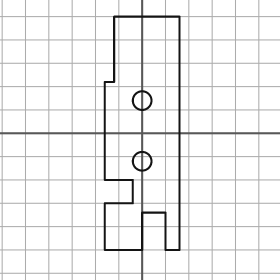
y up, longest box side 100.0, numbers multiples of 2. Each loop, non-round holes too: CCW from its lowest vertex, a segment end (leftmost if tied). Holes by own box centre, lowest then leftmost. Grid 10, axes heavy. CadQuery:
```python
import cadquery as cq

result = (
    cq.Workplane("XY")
    .moveTo(-16.0, -50.0)
    .lineTo(0.0, -50.0)
    .lineTo(0.0, -34.0)
    .lineTo(10.0, -34.0)
    .lineTo(10.0, -50.0)
    .lineTo(16.0, -50.0)
    .lineTo(16.0, 50.0)
    .lineTo(-12.0, 50.0)
    .lineTo(-12.0, 22.0)
    .lineTo(-16.0, 22.0)
    .lineTo(-16.0, -20.0)
    .lineTo(-4.0, -20.0)
    .lineTo(-4.0, -30.0)
    .lineTo(-16.0, -30.0)
    .close()
    .moveTo(0.0, -12.0)
    .circle(4.0)
    .moveTo(0.0, 14.0)
    .circle(4.0)
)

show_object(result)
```